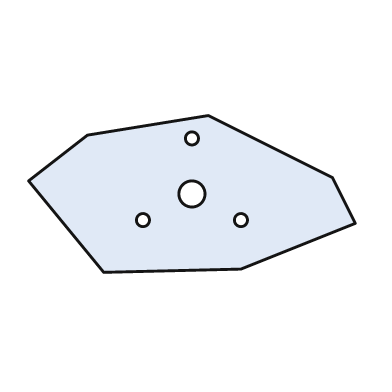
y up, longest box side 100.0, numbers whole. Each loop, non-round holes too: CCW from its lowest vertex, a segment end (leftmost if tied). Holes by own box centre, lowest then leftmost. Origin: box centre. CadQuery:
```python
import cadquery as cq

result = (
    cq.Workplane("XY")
    .moveTo(-27.0, -24.0)
    .lineTo(15.0, -23.0)
    .lineTo(50.0, -9.0)
    .lineTo(43.0, 5.0)
    .lineTo(5.0, 24.0)
    .lineTo(-32.0, 18.0)
    .lineTo(-50.0, 4.0)
    .close()
    .moveTo(-15.0, -8.0)
    .circle(2.0)
    .moveTo(15.0, -8.0)
    .circle(2.0)
    .moveTo(0.0, 0.0)
    .circle(4.0)
    .moveTo(0.0, 17.0)
    .circle(2.0)
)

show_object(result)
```